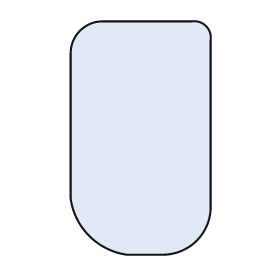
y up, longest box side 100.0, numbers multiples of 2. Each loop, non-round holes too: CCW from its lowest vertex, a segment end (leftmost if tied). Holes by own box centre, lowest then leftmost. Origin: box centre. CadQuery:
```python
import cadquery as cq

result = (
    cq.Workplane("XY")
    .moveTo(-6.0, -50.0)
    .lineTo(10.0, -50.0)
    .threePointArc((24.0, -44.0), (30.0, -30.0))
    .lineTo(30.0, 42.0)
    .threePointArc((28.0, 48.0), (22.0, 50.0))
    .lineTo(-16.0, 50.0)
    .threePointArc((-26.0, 46.0), (-30.0, 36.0))
    .lineTo(-30.0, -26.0)
    .threePointArc((-22.0, -42.0), (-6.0, -50.0))
    .close()
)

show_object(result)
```